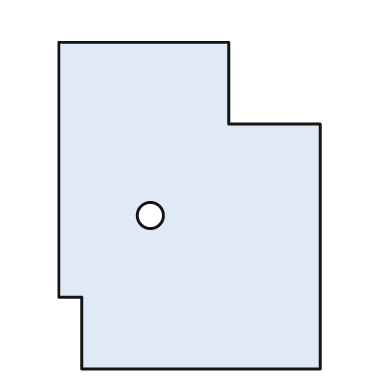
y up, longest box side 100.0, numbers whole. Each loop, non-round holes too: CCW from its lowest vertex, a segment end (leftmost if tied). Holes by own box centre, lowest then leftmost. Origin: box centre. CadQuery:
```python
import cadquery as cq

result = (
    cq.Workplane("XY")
    .moveTo(-33.0, -50.0)
    .lineTo(40.0, -50.0)
    .lineTo(40.0, 25.0)
    .lineTo(12.0, 25.0)
    .lineTo(12.0, 50.0)
    .lineTo(-40.0, 50.0)
    .lineTo(-40.0, -28.0)
    .lineTo(-33.0, -28.0)
    .close()
    .moveTo(-12.0, -3.0)
    .circle(4.0)
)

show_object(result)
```